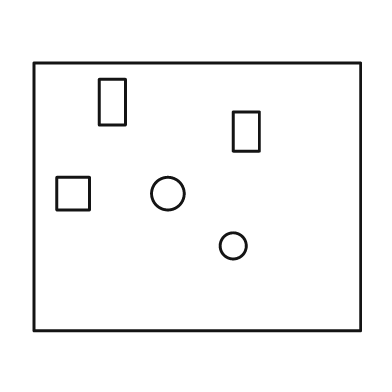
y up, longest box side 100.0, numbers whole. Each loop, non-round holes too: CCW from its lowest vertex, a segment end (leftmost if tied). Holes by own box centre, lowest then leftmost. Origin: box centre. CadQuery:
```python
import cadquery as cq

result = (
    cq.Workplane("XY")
    .moveTo(-50.0, -41.0)
    .lineTo(50.0, -41.0)
    .lineTo(50.0, 41.0)
    .lineTo(-50.0, 41.0)
    .close()
    .moveTo(11.0, -15.0)
    .circle(4.0)
    .moveTo(-43.0, -4.0)
    .lineTo(-33.0, -4.0)
    .lineTo(-33.0, 6.0)
    .lineTo(-43.0, 6.0)
    .close()
    .moveTo(-9.0, 1.0)
    .circle(5.0)
    .moveTo(11.0, 14.0)
    .lineTo(19.0, 14.0)
    .lineTo(19.0, 26.0)
    .lineTo(11.0, 26.0)
    .close()
    .moveTo(-30.0, 22.0)
    .lineTo(-22.0, 22.0)
    .lineTo(-22.0, 36.0)
    .lineTo(-30.0, 36.0)
    .close()
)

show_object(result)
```